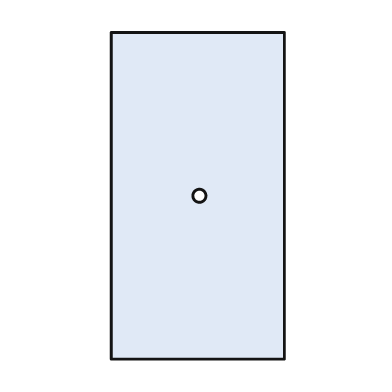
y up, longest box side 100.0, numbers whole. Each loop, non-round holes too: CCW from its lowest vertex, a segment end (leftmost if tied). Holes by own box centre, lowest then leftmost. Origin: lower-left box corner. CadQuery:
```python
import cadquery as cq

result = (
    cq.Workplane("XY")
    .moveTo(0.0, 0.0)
    .lineTo(53.0, 0.0)
    .lineTo(53.0, 100.0)
    .lineTo(0.0, 100.0)
    .close()
    .moveTo(27.0, 50.0)
    .circle(2.0)
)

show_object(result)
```